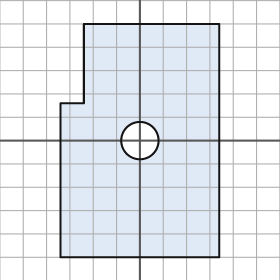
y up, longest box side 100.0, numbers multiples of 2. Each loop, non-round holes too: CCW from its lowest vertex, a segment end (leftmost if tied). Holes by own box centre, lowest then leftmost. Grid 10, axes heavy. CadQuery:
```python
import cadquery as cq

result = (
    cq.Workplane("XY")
    .moveTo(-34.0, -50.0)
    .lineTo(34.0, -50.0)
    .lineTo(34.0, 50.0)
    .lineTo(-24.0, 50.0)
    .lineTo(-24.0, 16.0)
    .lineTo(-34.0, 16.0)
    .close()
    .moveTo(0.0, 0.0)
    .circle(8.0)
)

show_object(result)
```